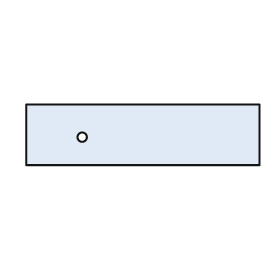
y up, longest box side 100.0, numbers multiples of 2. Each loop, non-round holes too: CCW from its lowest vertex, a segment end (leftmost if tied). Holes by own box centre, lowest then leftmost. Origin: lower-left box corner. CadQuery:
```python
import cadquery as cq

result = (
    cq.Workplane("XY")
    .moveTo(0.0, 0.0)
    .lineTo(100.0, 0.0)
    .lineTo(100.0, 26.0)
    .lineTo(0.0, 26.0)
    .close()
    .moveTo(24.0, 12.0)
    .circle(2.0)
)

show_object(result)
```